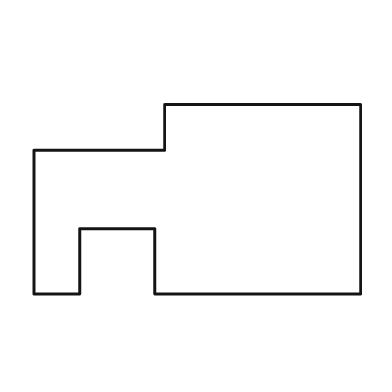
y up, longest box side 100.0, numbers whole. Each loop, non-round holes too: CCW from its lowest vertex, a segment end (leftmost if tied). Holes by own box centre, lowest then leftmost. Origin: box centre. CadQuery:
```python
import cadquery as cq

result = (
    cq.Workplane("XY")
    .moveTo(-50.0, -29.0)
    .lineTo(-36.0, -29.0)
    .lineTo(-36.0, -9.0)
    .lineTo(-13.0, -9.0)
    .lineTo(-13.0, -29.0)
    .lineTo(50.0, -29.0)
    .lineTo(50.0, 29.0)
    .lineTo(-10.0, 29.0)
    .lineTo(-10.0, 15.0)
    .lineTo(-50.0, 15.0)
    .close()
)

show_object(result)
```